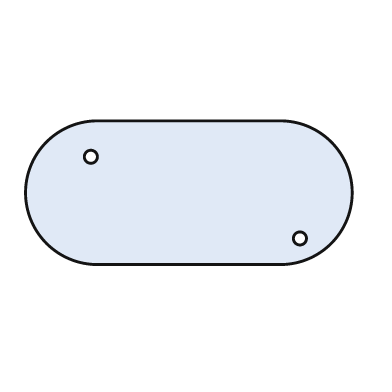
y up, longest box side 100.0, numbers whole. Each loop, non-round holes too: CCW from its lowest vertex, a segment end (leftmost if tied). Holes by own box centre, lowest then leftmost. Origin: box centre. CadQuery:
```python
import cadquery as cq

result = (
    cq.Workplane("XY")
    .moveTo(-28.0, -22.0)
    .lineTo(28.0, -22.0)
    .threePointArc((50.0, 0.0), (28.0, 22.0))
    .lineTo(-28.0, 22.0)
    .threePointArc((-50.0, 0.0), (-28.0, -22.0))
    .close()
    .moveTo(34.0, -14.0)
    .circle(2.0)
    .moveTo(-30.0, 11.0)
    .circle(2.0)
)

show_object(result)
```